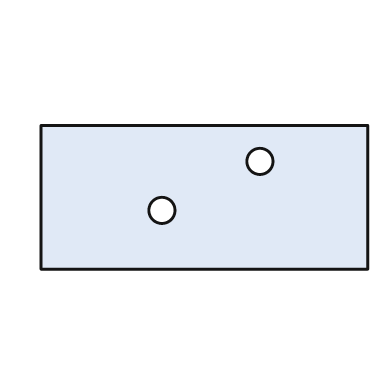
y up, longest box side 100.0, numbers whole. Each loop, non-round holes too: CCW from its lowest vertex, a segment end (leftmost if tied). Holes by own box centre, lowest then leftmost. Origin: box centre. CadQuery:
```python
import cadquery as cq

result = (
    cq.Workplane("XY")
    .moveTo(-50.0, -22.0)
    .lineTo(50.0, -22.0)
    .lineTo(50.0, 22.0)
    .lineTo(-50.0, 22.0)
    .close()
    .moveTo(-13.0, -4.0)
    .circle(4.0)
    .moveTo(17.0, 11.0)
    .circle(4.0)
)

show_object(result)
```